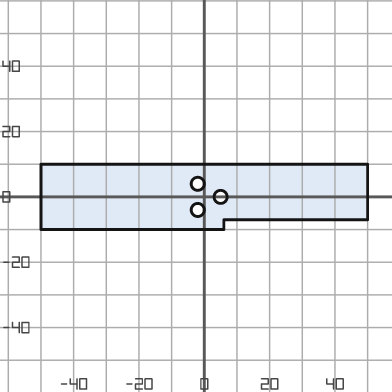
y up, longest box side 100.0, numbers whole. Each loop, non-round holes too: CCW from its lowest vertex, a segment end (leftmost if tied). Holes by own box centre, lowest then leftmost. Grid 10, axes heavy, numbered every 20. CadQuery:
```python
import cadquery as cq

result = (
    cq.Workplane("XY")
    .moveTo(-50.0, -10.0)
    .lineTo(6.0, -10.0)
    .lineTo(6.0, -7.0)
    .lineTo(50.0, -7.0)
    .lineTo(50.0, 10.0)
    .lineTo(-50.0, 10.0)
    .close()
    .moveTo(-2.0, -4.0)
    .circle(2.0)
    .moveTo(5.0, 0.0)
    .circle(2.0)
    .moveTo(-2.0, 4.0)
    .circle(2.0)
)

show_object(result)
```